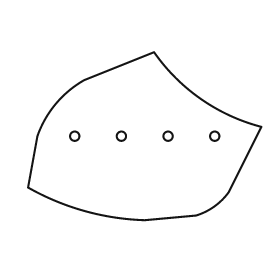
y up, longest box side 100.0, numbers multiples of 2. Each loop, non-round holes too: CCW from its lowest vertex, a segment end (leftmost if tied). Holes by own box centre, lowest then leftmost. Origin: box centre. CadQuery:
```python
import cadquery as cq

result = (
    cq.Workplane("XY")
    .moveTo(0.0, -36.0)
    .lineTo(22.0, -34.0)
    .threePointArc((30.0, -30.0), (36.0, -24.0))
    .lineTo(50.0, 4.0)
    .threePointArc((24.0, 16.0), (4.0, 36.0))
    .lineTo(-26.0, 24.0)
    .threePointArc((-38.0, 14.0), (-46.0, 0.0))
    .lineTo(-50.0, -22.0)
    .threePointArc((-26.0, -32.0), (0.0, -36.0))
    .close()
    .moveTo(-30.0, 0.0)
    .circle(2.0)
    .moveTo(-10.0, 0.0)
    .circle(2.0)
    .moveTo(10.0, 0.0)
    .circle(2.0)
    .moveTo(30.0, 0.0)
    .circle(2.0)
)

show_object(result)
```